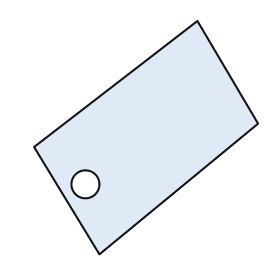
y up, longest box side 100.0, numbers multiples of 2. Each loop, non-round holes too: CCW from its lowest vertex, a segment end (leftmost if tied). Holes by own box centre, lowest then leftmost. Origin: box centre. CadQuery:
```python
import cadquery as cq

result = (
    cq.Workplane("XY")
    .moveTo(-20.0, -50.0)
    .lineTo(48.0, 6.0)
    .lineTo(22.0, 50.0)
    .lineTo(-48.0, -4.0)
    .close()
    .moveTo(-26.0, -20.0)
    .circle(6.0)
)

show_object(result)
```